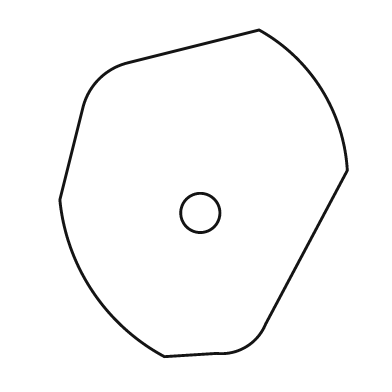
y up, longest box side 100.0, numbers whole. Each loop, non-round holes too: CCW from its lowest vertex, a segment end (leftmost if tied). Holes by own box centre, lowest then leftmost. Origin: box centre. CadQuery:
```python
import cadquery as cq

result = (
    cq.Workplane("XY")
    .moveTo(-12.0, -50.0)
    .lineTo(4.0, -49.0)
    .threePointArc((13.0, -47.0), (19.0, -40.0))
    .lineTo(44.0, 7.0)
    .threePointArc((36.0, 32.0), (17.0, 50.0))
    .lineTo(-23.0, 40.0)
    .threePointArc((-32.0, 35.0), (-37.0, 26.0))
    .lineTo(-44.0, -2.0)
    .threePointArc((-34.0, -30.0), (-12.0, -50.0))
    .close()
    .moveTo(-1.0, -6.0)
    .circle(6.0)
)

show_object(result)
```